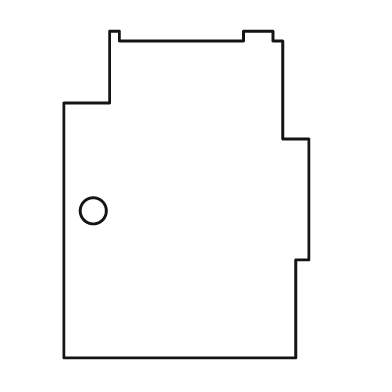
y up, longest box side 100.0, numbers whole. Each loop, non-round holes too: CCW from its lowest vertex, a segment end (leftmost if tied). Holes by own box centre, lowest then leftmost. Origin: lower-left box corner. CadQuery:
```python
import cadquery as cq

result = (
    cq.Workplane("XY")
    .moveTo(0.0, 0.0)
    .lineTo(71.0, 0.0)
    .lineTo(71.0, 30.0)
    .lineTo(75.0, 30.0)
    .lineTo(75.0, 67.0)
    .lineTo(67.0, 67.0)
    .lineTo(67.0, 97.0)
    .lineTo(64.0, 97.0)
    .lineTo(64.0, 100.0)
    .lineTo(55.0, 100.0)
    .lineTo(55.0, 97.0)
    .lineTo(17.0, 97.0)
    .lineTo(17.0, 100.0)
    .lineTo(14.0, 100.0)
    .lineTo(14.0, 78.0)
    .lineTo(0.0, 78.0)
    .close()
    .moveTo(9.0, 45.0)
    .circle(4.0)
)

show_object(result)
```